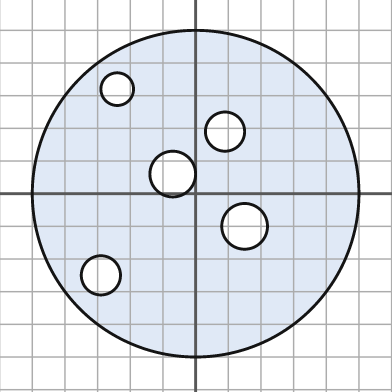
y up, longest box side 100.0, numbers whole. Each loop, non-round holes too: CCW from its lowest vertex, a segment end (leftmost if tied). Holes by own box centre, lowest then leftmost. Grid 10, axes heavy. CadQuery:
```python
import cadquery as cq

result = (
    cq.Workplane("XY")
    .moveTo(0.0, 0.0)
    .circle(50.0)
    .moveTo(-29.0, -25.0)
    .circle(6.0)
    .moveTo(15.0, -10.0)
    .circle(7.0)
    .moveTo(-7.0, 6.0)
    .circle(7.0)
    .moveTo(9.0, 19.0)
    .circle(6.0)
    .moveTo(-24.0, 32.0)
    .circle(5.0)
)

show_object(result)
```